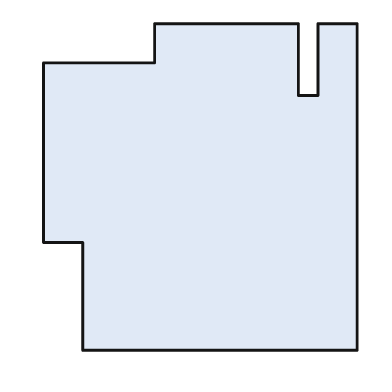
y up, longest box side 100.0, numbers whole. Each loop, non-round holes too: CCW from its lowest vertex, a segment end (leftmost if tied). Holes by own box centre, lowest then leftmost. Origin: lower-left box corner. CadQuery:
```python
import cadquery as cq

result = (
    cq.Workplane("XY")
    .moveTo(12.0, 0.0)
    .lineTo(96.0, 0.0)
    .lineTo(96.0, 100.0)
    .lineTo(84.0, 100.0)
    .lineTo(84.0, 78.0)
    .lineTo(78.0, 78.0)
    .lineTo(78.0, 100.0)
    .lineTo(34.0, 100.0)
    .lineTo(34.0, 88.0)
    .lineTo(0.0, 88.0)
    .lineTo(0.0, 33.0)
    .lineTo(12.0, 33.0)
    .close()
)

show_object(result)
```